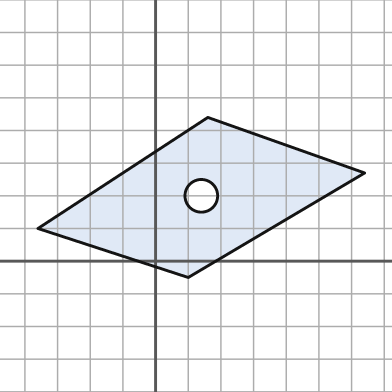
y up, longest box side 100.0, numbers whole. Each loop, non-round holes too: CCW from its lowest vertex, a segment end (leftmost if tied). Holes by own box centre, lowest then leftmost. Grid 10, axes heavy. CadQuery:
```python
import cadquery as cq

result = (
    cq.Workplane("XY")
    .moveTo(10.0, -5.0)
    .lineTo(64.0, 27.0)
    .lineTo(16.0, 44.0)
    .lineTo(-36.0, 10.0)
    .close()
    .moveTo(14.0, 20.0)
    .circle(5.0)
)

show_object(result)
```